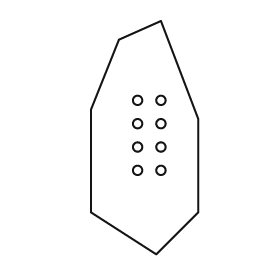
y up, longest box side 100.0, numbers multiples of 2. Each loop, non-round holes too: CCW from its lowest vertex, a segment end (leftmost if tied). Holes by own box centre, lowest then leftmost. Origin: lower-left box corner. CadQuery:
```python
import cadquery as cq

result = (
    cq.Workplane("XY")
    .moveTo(28.0, 0.0)
    .lineTo(46.0, 18.0)
    .lineTo(46.0, 58.0)
    .lineTo(30.0, 100.0)
    .lineTo(12.0, 92.0)
    .lineTo(0.0, 62.0)
    .lineTo(0.0, 18.0)
    .close()
    .moveTo(20.0, 36.0)
    .circle(2.0)
    .moveTo(30.0, 36.0)
    .circle(2.0)
    .moveTo(20.0, 46.0)
    .circle(2.0)
    .moveTo(30.0, 46.0)
    .circle(2.0)
    .moveTo(20.0, 56.0)
    .circle(2.0)
    .moveTo(30.0, 56.0)
    .circle(2.0)
    .moveTo(20.0, 66.0)
    .circle(2.0)
    .moveTo(30.0, 66.0)
    .circle(2.0)
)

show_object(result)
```